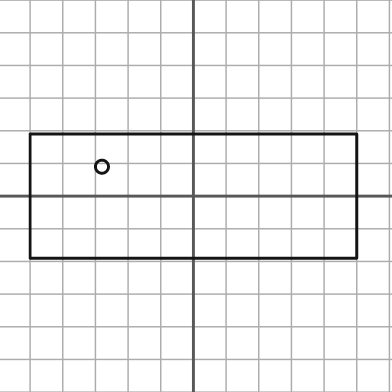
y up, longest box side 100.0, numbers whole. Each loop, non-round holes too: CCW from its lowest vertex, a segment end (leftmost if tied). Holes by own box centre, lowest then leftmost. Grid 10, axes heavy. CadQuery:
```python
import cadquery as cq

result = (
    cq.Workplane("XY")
    .moveTo(-50.0, -19.0)
    .lineTo(50.0, -19.0)
    .lineTo(50.0, 19.0)
    .lineTo(-50.0, 19.0)
    .close()
    .moveTo(-28.0, 9.0)
    .circle(2.0)
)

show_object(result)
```